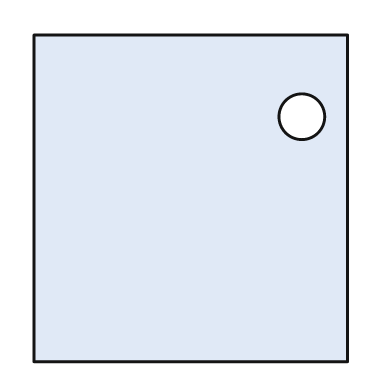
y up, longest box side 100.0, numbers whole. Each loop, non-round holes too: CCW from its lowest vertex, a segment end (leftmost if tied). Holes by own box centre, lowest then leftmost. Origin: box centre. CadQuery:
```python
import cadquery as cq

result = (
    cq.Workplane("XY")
    .moveTo(-48.0, -50.0)
    .lineTo(48.0, -50.0)
    .lineTo(48.0, 50.0)
    .lineTo(-48.0, 50.0)
    .close()
    .moveTo(34.0, 25.0)
    .circle(7.0)
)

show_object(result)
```